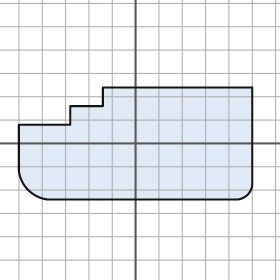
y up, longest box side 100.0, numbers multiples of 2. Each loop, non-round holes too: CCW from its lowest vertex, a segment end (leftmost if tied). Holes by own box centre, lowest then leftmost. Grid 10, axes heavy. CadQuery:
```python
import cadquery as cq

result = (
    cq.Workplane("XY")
    .moveTo(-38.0, -24.0)
    .lineTo(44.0, -24.0)
    .threePointArc((48.0, -22.0), (50.0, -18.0))
    .lineTo(50.0, 24.0)
    .lineTo(-14.0, 24.0)
    .lineTo(-14.0, 16.0)
    .lineTo(-28.0, 16.0)
    .lineTo(-28.0, 8.0)
    .lineTo(-50.0, 8.0)
    .lineTo(-50.0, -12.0)
    .threePointArc((-46.0, -20.0), (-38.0, -24.0))
    .close()
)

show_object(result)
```